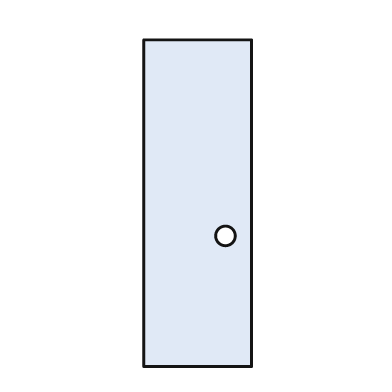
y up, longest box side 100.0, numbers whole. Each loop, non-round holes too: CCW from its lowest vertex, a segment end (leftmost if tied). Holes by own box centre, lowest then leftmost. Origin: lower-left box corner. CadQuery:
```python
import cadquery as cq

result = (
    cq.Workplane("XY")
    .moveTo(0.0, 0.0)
    .lineTo(33.0, 0.0)
    .lineTo(33.0, 100.0)
    .lineTo(0.0, 100.0)
    .close()
    .moveTo(25.0, 40.0)
    .circle(3.0)
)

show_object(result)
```